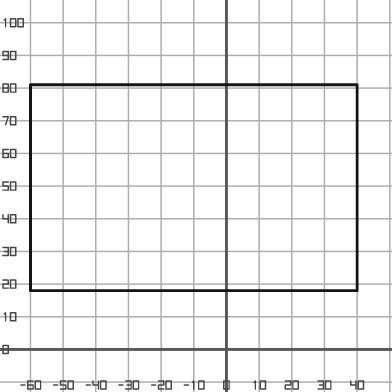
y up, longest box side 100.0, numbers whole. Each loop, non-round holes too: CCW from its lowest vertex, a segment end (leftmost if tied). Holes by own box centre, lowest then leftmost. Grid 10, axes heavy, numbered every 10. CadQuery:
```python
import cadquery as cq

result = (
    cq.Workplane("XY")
    .moveTo(-60.0, 18.0)
    .lineTo(40.0, 18.0)
    .lineTo(40.0, 81.0)
    .lineTo(-60.0, 81.0)
    .close()
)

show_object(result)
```